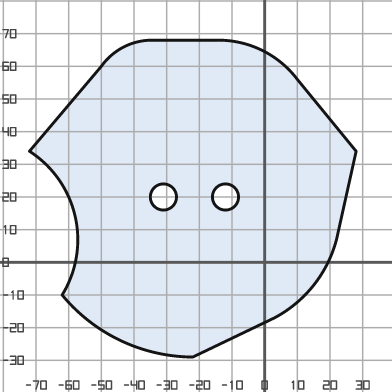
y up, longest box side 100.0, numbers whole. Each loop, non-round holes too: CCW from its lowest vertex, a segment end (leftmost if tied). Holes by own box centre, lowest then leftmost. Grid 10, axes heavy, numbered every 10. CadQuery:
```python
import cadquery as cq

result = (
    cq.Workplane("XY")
    .moveTo(-22.0, -29.0)
    .lineTo(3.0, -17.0)
    .threePointArc((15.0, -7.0), (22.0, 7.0))
    .lineTo(28.0, 34.0)
    .lineTo(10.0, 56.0)
    .threePointArc((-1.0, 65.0), (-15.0, 68.0))
    .lineTo(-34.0, 68.0)
    .threePointArc((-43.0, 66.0), (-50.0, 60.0))
    .lineTo(-72.0, 34.0)
    .threePointArc((-58.0, 14.0), (-62.0, -10.0))
    .threePointArc((-44.0, -24.0), (-22.0, -29.0))
    .close()
    .moveTo(-31.0, 20.0)
    .circle(4.0)
    .moveTo(-12.0, 20.0)
    .circle(4.0)
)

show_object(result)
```